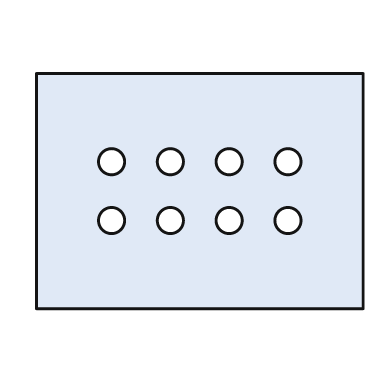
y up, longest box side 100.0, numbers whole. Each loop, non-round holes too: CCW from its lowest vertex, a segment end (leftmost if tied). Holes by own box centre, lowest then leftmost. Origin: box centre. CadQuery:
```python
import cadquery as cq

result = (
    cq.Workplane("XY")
    .moveTo(-50.0, -36.0)
    .lineTo(50.0, -36.0)
    .lineTo(50.0, 36.0)
    .lineTo(-50.0, 36.0)
    .close()
    .moveTo(-27.0, -9.0)
    .circle(4.0)
    .moveTo(-9.0, -9.0)
    .circle(4.0)
    .moveTo(9.0, -9.0)
    .circle(4.0)
    .moveTo(27.0, -9.0)
    .circle(4.0)
    .moveTo(-27.0, 9.0)
    .circle(4.0)
    .moveTo(-9.0, 9.0)
    .circle(4.0)
    .moveTo(9.0, 9.0)
    .circle(4.0)
    .moveTo(27.0, 9.0)
    .circle(4.0)
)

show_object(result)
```